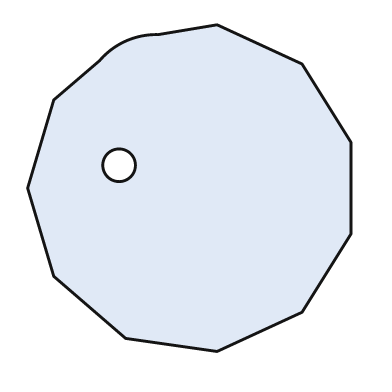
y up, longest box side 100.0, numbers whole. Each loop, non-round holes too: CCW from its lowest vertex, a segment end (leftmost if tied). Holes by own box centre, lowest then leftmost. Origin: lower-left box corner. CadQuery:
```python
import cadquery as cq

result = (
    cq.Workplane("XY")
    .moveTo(58.0, 0.0)
    .lineTo(84.0, 12.0)
    .lineTo(99.0, 36.0)
    .lineTo(99.0, 64.0)
    .lineTo(84.0, 88.0)
    .lineTo(58.0, 100.0)
    .lineTo(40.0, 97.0)
    .threePointArc((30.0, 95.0), (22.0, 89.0))
    .lineTo(8.0, 77.0)
    .lineTo(0.0, 50.0)
    .lineTo(8.0, 23.0)
    .lineTo(30.0, 4.0)
    .close()
    .moveTo(28.0, 57.0)
    .circle(5.0)
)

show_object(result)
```